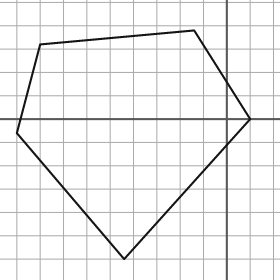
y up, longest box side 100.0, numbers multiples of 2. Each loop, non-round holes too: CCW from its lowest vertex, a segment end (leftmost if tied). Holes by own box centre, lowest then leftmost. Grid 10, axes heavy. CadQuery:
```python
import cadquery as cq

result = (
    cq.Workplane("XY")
    .moveTo(-44.0, -60.0)
    .lineTo(10.0, 0.0)
    .lineTo(-14.0, 38.0)
    .lineTo(-80.0, 32.0)
    .lineTo(-90.0, -6.0)
    .close()
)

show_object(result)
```